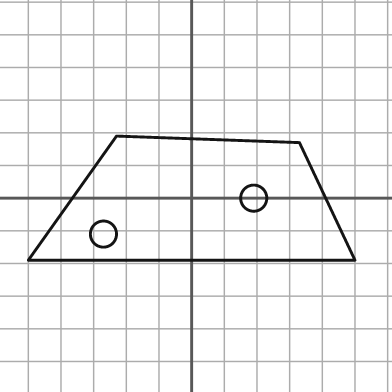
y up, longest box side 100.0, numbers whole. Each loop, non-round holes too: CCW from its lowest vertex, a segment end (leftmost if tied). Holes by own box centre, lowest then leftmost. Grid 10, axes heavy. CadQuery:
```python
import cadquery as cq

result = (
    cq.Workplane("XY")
    .moveTo(-50.0, -19.0)
    .lineTo(50.0, -19.0)
    .lineTo(33.0, 17.0)
    .lineTo(-23.0, 19.0)
    .close()
    .moveTo(-27.0, -11.0)
    .circle(4.0)
    .moveTo(19.0, 0.0)
    .circle(4.0)
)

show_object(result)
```